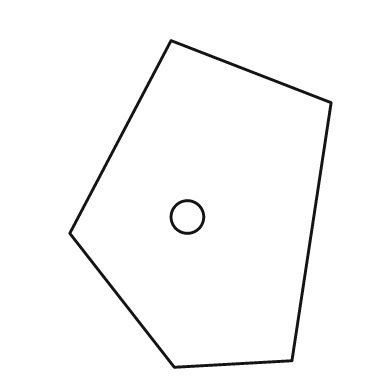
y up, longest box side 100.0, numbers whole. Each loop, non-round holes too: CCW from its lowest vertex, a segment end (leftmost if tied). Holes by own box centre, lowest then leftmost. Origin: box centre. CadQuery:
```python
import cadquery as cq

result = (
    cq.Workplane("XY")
    .moveTo(-8.0, -50.0)
    .lineTo(28.0, -48.0)
    .lineTo(40.0, 31.0)
    .lineTo(-9.0, 50.0)
    .lineTo(-40.0, -9.0)
    .close()
    .moveTo(-4.0, -4.0)
    .circle(5.0)
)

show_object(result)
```